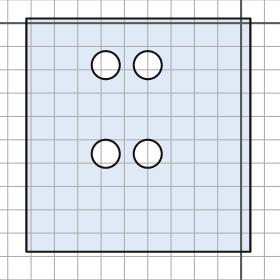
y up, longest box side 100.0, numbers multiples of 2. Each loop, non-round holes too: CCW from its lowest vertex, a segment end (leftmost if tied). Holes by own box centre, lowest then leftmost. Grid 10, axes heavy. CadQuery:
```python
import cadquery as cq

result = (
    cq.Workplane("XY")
    .moveTo(-92.0, -98.0)
    .lineTo(4.0, -98.0)
    .lineTo(4.0, 2.0)
    .lineTo(-92.0, 2.0)
    .close()
    .moveTo(-58.0, -56.0)
    .circle(6.0)
    .moveTo(-40.0, -56.0)
    .circle(6.0)
    .moveTo(-58.0, -18.0)
    .circle(6.0)
    .moveTo(-40.0, -18.0)
    .circle(6.0)
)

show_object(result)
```